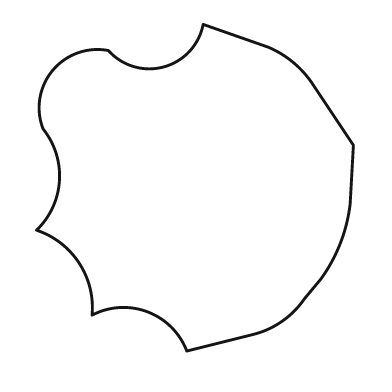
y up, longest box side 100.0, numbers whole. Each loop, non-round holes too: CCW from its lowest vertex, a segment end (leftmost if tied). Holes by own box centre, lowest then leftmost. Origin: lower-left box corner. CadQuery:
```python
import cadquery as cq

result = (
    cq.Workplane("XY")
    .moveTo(46.0, 0.0)
    .lineTo(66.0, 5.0)
    .threePointArc((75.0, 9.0), (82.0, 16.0))
    .lineTo(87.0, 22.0)
    .threePointArc((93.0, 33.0), (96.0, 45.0))
    .lineTo(97.0, 63.0)
    .lineTo(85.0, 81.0)
    .threePointArc((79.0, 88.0), (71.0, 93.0))
    .lineTo(51.0, 100.0)
    .threePointArc((39.0, 87.0), (22.0, 92.0))
    .threePointArc((5.0, 86.0), (2.0, 68.0))
    .threePointArc((7.0, 52.0), (0.0, 37.0))
    .threePointArc((13.0, 27.0), (17.0, 11.0))
    .threePointArc((34.0, 12.0), (46.0, 0.0))
    .close()
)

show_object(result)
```